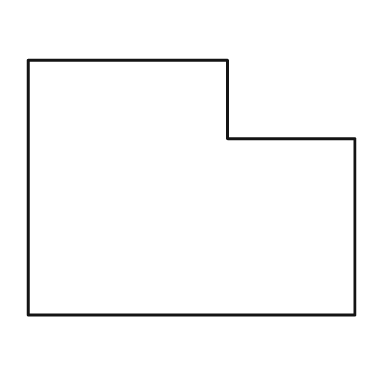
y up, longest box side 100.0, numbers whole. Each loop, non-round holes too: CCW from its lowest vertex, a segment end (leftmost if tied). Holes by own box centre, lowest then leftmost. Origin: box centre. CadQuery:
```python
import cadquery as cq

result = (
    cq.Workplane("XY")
    .moveTo(-50.0, -39.0)
    .lineTo(50.0, -39.0)
    .lineTo(50.0, 15.0)
    .lineTo(11.0, 15.0)
    .lineTo(11.0, 39.0)
    .lineTo(-50.0, 39.0)
    .close()
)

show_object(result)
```